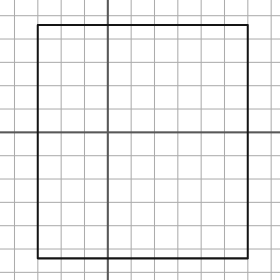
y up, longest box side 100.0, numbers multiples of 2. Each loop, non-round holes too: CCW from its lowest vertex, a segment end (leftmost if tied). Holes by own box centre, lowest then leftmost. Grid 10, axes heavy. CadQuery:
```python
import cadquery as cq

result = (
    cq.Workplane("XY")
    .moveTo(-30.0, -54.0)
    .lineTo(60.0, -54.0)
    .lineTo(60.0, 46.0)
    .lineTo(-30.0, 46.0)
    .close()
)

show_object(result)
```